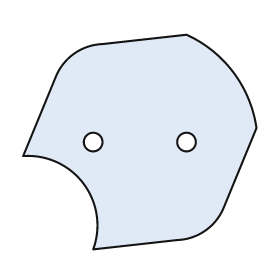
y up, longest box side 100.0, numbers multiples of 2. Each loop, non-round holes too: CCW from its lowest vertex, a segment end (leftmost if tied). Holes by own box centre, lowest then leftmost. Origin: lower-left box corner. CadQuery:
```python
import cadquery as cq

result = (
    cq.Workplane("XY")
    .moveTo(30.0, 0.0)
    .lineTo(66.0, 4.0)
    .threePointArc((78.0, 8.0), (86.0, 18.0))
    .lineTo(100.0, 52.0)
    .threePointArc((90.0, 76.0), (70.0, 92.0))
    .lineTo(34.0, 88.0)
    .threePointArc((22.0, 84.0), (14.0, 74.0))
    .lineTo(0.0, 40.0)
    .threePointArc((26.0, 28.0), (30.0, 0.0))
    .close()
    .moveTo(30.0, 46.0)
    .circle(4.0)
    .moveTo(70.0, 46.0)
    .circle(4.0)
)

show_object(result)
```